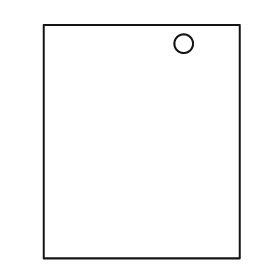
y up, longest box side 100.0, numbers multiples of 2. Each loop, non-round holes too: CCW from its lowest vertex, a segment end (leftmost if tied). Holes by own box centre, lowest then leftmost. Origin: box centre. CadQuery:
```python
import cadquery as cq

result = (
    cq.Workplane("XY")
    .moveTo(-42.0, -50.0)
    .lineTo(42.0, -50.0)
    .lineTo(42.0, 50.0)
    .lineTo(-42.0, 50.0)
    .close()
    .moveTo(18.0, 42.0)
    .circle(4.0)
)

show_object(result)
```